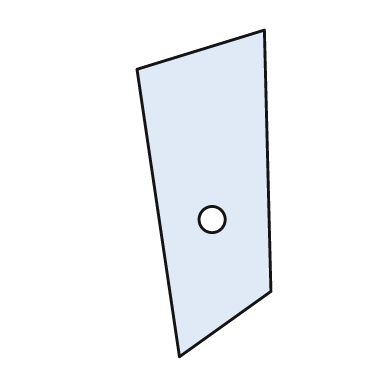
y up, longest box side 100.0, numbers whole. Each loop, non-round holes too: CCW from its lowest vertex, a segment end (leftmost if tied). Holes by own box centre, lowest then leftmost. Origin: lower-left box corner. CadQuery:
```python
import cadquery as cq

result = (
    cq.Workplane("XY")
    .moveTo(13.0, 0.0)
    .lineTo(41.0, 20.0)
    .lineTo(39.0, 100.0)
    .lineTo(0.0, 88.0)
    .close()
    .moveTo(23.0, 42.0)
    .circle(4.0)
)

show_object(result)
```